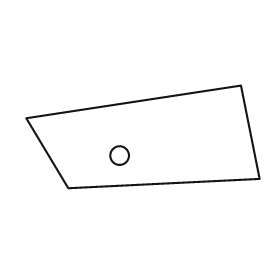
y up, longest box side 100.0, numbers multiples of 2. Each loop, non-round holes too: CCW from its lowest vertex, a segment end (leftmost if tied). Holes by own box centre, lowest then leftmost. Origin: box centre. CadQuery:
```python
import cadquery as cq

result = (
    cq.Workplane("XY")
    .moveTo(-32.0, -22.0)
    .lineTo(50.0, -18.0)
    .lineTo(42.0, 22.0)
    .lineTo(-50.0, 8.0)
    .close()
    .moveTo(-10.0, -8.0)
    .circle(4.0)
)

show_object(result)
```